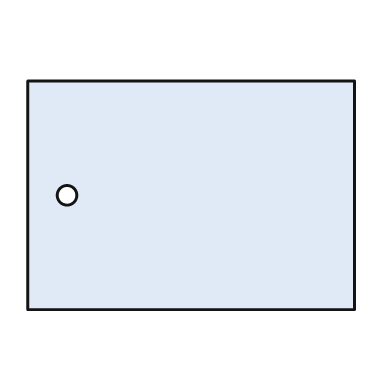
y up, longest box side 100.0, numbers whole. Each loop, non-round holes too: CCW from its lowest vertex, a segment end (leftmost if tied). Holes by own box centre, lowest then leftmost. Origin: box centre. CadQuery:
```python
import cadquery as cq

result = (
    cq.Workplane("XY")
    .moveTo(-50.0, -35.0)
    .lineTo(50.0, -35.0)
    .lineTo(50.0, 35.0)
    .lineTo(-50.0, 35.0)
    .close()
    .moveTo(-38.0, 0.0)
    .circle(3.0)
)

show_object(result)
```